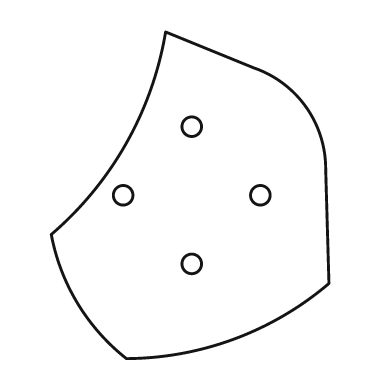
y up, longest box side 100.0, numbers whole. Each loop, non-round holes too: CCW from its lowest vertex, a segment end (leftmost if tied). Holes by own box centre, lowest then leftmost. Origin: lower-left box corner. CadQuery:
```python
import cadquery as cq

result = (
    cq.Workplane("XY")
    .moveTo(23.0, 0.0)
    .threePointArc((56.0, 6.0), (85.0, 23.0))
    .lineTo(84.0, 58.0)
    .threePointArc((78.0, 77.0), (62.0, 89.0))
    .lineTo(35.0, 100.0)
    .threePointArc((23.0, 66.0), (0.0, 38.0))
    .threePointArc((8.0, 17.0), (23.0, 0.0))
    .close()
    .moveTo(43.0, 29.0)
    .circle(3.0)
    .moveTo(22.0, 50.0)
    .circle(3.0)
    .moveTo(64.0, 50.0)
    .circle(3.0)
    .moveTo(43.0, 71.0)
    .circle(3.0)
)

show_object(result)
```